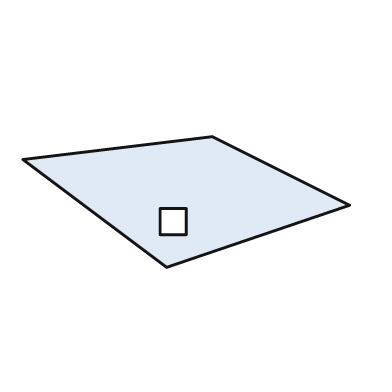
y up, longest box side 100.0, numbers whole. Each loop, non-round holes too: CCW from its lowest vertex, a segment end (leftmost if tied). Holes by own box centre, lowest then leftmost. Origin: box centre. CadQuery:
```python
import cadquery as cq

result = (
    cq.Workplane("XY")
    .moveTo(-6.0, -20.0)
    .lineTo(50.0, -1.0)
    .lineTo(8.0, 20.0)
    .lineTo(-50.0, 13.0)
    .close()
    .moveTo(-8.0, -10.0)
    .lineTo(0.0, -10.0)
    .lineTo(0.0, -2.0)
    .lineTo(-8.0, -2.0)
    .close()
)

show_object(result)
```